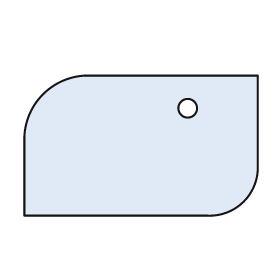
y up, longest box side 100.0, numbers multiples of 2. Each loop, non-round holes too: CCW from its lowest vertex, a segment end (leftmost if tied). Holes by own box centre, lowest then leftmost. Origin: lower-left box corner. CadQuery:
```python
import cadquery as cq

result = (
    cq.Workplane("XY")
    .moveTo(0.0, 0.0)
    .lineTo(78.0, 0.0)
    .threePointArc((94.0, 6.0), (100.0, 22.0))
    .lineTo(100.0, 60.0)
    .lineTo(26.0, 60.0)
    .threePointArc((8.0, 52.0), (0.0, 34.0))
    .close()
    .moveTo(70.0, 46.0)
    .circle(4.0)
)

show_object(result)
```